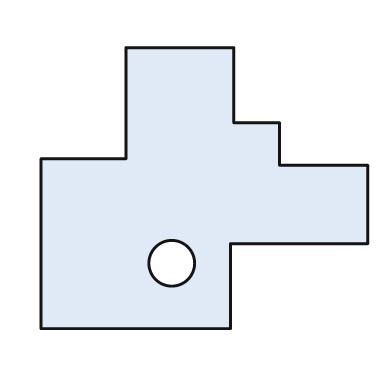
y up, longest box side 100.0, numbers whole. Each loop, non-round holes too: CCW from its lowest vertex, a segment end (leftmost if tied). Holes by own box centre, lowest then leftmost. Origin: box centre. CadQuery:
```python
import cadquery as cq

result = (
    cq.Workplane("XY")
    .moveTo(-50.0, -43.0)
    .lineTo(8.0, -43.0)
    .lineTo(8.0, -17.0)
    .lineTo(50.0, -17.0)
    .lineTo(50.0, 7.0)
    .lineTo(23.0, 7.0)
    .lineTo(23.0, 20.0)
    .lineTo(9.0, 20.0)
    .lineTo(9.0, 43.0)
    .lineTo(-24.0, 43.0)
    .lineTo(-24.0, 9.0)
    .lineTo(-50.0, 9.0)
    .close()
    .moveTo(-10.0, -23.0)
    .circle(7.0)
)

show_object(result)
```